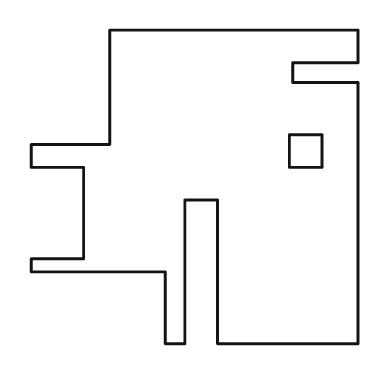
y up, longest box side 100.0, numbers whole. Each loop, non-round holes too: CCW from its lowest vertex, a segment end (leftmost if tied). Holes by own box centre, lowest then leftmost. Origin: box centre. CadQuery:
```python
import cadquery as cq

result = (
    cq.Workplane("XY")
    .moveTo(-9.0, -48.0)
    .lineTo(-3.0, -48.0)
    .lineTo(-3.0, -4.0)
    .lineTo(7.0, -4.0)
    .lineTo(7.0, -48.0)
    .lineTo(50.0, -48.0)
    .lineTo(50.0, 32.0)
    .lineTo(30.0, 32.0)
    .lineTo(30.0, 38.0)
    .lineTo(50.0, 38.0)
    .lineTo(50.0, 48.0)
    .lineTo(-26.0, 48.0)
    .lineTo(-26.0, 13.0)
    .lineTo(-50.0, 13.0)
    .lineTo(-50.0, 6.0)
    .lineTo(-34.0, 6.0)
    .lineTo(-34.0, -22.0)
    .lineTo(-50.0, -22.0)
    .lineTo(-50.0, -26.0)
    .lineTo(-9.0, -26.0)
    .close()
    .moveTo(29.0, 6.0)
    .lineTo(39.0, 6.0)
    .lineTo(39.0, 16.0)
    .lineTo(29.0, 16.0)
    .close()
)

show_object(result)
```